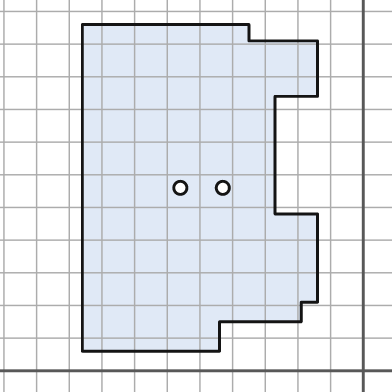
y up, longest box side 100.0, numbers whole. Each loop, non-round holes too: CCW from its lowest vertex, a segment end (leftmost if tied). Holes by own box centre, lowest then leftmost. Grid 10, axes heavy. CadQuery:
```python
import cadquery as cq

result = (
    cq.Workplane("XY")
    .moveTo(-86.0, 6.0)
    .lineTo(-44.0, 6.0)
    .lineTo(-44.0, 15.0)
    .lineTo(-19.0, 15.0)
    .lineTo(-19.0, 21.0)
    .lineTo(-14.0, 21.0)
    .lineTo(-14.0, 48.0)
    .lineTo(-27.0, 48.0)
    .lineTo(-27.0, 84.0)
    .lineTo(-14.0, 84.0)
    .lineTo(-14.0, 101.0)
    .lineTo(-35.0, 101.0)
    .lineTo(-35.0, 106.0)
    .lineTo(-86.0, 106.0)
    .close()
    .moveTo(-56.0, 56.0)
    .circle(2.0)
    .moveTo(-43.0, 56.0)
    .circle(2.0)
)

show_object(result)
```